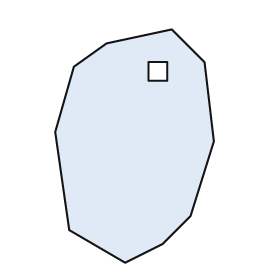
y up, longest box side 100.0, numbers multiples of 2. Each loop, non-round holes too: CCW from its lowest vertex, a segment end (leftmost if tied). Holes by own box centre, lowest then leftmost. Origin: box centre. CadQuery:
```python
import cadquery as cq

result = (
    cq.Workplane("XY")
    .moveTo(-4.0, -50.0)
    .lineTo(12.0, -42.0)
    .lineTo(24.0, -30.0)
    .lineTo(34.0, 2.0)
    .lineTo(30.0, 36.0)
    .lineTo(16.0, 50.0)
    .lineTo(-12.0, 44.0)
    .lineTo(-26.0, 34.0)
    .lineTo(-34.0, 6.0)
    .lineTo(-28.0, -36.0)
    .close()
    .moveTo(6.0, 28.0)
    .lineTo(14.0, 28.0)
    .lineTo(14.0, 36.0)
    .lineTo(6.0, 36.0)
    .close()
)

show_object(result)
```